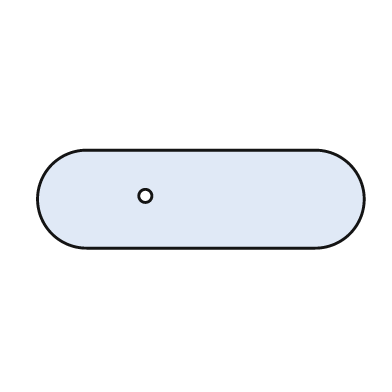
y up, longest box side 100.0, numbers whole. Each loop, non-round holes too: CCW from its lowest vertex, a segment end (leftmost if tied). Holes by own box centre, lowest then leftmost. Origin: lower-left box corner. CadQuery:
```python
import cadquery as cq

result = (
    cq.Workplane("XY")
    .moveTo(15.0, 0.0)
    .lineTo(85.0, 0.0)
    .threePointArc((100.0, 15.0), (85.0, 30.0))
    .lineTo(15.0, 30.0)
    .threePointArc((0.0, 15.0), (15.0, 0.0))
    .close()
    .moveTo(33.0, 16.0)
    .circle(2.0)
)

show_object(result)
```